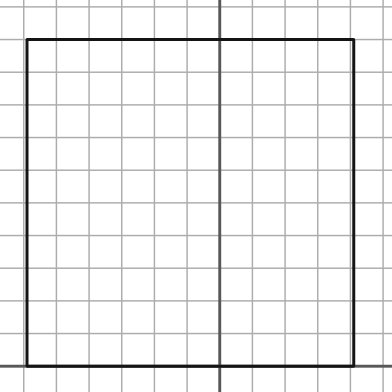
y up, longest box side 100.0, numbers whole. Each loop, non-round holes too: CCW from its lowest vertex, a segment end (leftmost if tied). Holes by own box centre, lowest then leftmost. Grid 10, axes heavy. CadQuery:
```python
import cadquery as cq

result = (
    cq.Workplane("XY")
    .moveTo(-59.0, 0.0)
    .lineTo(41.0, 0.0)
    .lineTo(41.0, 100.0)
    .lineTo(-59.0, 100.0)
    .close()
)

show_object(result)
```